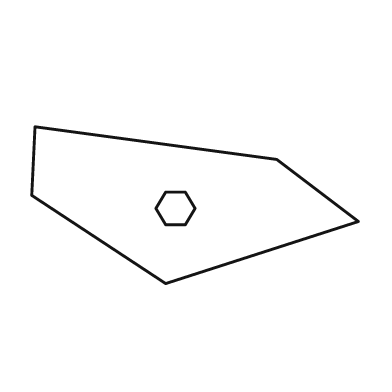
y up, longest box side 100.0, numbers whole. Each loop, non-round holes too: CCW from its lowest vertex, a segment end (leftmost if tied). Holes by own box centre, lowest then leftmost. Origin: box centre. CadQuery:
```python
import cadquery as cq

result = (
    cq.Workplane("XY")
    .moveTo(-9.0, -24.0)
    .lineTo(50.0, -5.0)
    .lineTo(25.0, 14.0)
    .lineTo(-49.0, 24.0)
    .lineTo(-50.0, 3.0)
    .close()
    .moveTo(-9.0, -6.0)
    .lineTo(-3.0, -6.0)
    .lineTo(0.0, -1.0)
    .lineTo(-3.0, 4.0)
    .lineTo(-9.0, 4.0)
    .lineTo(-12.0, -1.0)
    .close()
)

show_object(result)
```